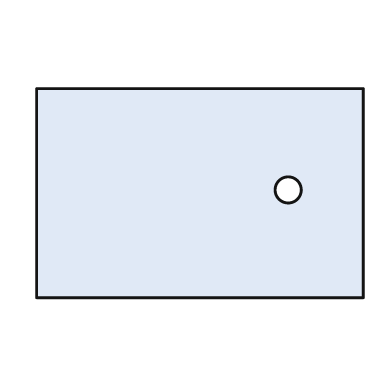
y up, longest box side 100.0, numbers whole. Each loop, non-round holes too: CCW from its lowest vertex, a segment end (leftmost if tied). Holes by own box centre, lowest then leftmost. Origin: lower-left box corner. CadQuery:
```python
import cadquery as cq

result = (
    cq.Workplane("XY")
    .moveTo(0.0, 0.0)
    .lineTo(100.0, 0.0)
    .lineTo(100.0, 64.0)
    .lineTo(0.0, 64.0)
    .close()
    .moveTo(77.0, 33.0)
    .circle(4.0)
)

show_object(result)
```